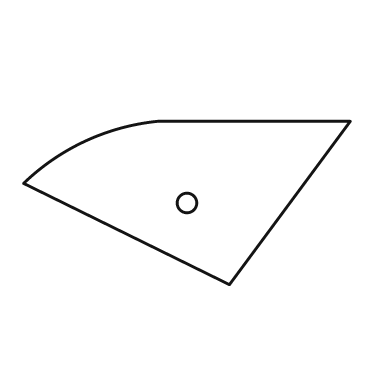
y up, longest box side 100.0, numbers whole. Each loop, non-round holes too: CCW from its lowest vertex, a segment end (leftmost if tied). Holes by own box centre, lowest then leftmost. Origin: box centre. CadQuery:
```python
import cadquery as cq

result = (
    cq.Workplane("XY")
    .moveTo(13.0, -25.0)
    .lineTo(50.0, 25.0)
    .lineTo(-9.0, 25.0)
    .threePointArc((-31.0, 19.0), (-50.0, 6.0))
    .close()
    .moveTo(0.0, 0.0)
    .circle(3.0)
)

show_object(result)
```